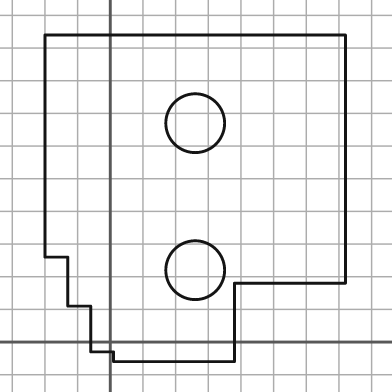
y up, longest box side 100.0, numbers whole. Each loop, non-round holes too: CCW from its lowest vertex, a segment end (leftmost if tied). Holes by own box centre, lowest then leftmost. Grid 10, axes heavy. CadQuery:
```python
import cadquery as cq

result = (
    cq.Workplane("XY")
    .moveTo(1.0, -6.0)
    .lineTo(38.0, -6.0)
    .lineTo(38.0, 18.0)
    .lineTo(72.0, 18.0)
    .lineTo(72.0, 94.0)
    .lineTo(-20.0, 94.0)
    .lineTo(-20.0, 26.0)
    .lineTo(-13.0, 26.0)
    .lineTo(-13.0, 11.0)
    .lineTo(-6.0, 11.0)
    .lineTo(-6.0, -3.0)
    .lineTo(1.0, -3.0)
    .close()
    .moveTo(26.0, 22.0)
    .circle(9.0)
    .moveTo(26.0, 67.0)
    .circle(9.0)
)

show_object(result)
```